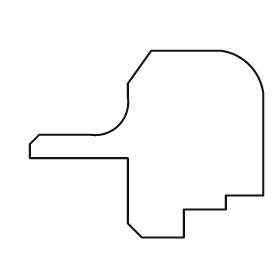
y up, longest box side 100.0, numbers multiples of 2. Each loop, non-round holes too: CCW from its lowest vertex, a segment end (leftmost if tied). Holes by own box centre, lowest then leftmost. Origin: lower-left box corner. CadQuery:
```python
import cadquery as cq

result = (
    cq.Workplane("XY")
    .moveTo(48.0, 0.0)
    .lineTo(66.0, 0.0)
    .lineTo(66.0, 12.0)
    .lineTo(84.0, 12.0)
    .lineTo(84.0, 18.0)
    .lineTo(100.0, 18.0)
    .lineTo(100.0, 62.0)
    .threePointArc((94.0, 74.0), (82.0, 80.0))
    .lineTo(52.0, 80.0)
    .lineTo(42.0, 66.0)
    .lineTo(42.0, 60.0)
    .threePointArc((38.0, 48.0), (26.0, 44.0))
    .lineTo(4.0, 44.0)
    .lineTo(0.0, 40.0)
    .lineTo(0.0, 34.0)
    .lineTo(42.0, 34.0)
    .lineTo(42.0, 6.0)
    .close()
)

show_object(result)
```